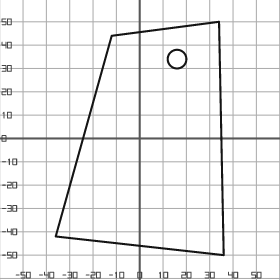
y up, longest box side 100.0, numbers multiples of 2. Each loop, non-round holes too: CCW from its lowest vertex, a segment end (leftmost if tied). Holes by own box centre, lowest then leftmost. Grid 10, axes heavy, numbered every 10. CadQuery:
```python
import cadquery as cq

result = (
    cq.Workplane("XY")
    .moveTo(36.0, -50.0)
    .lineTo(34.0, 50.0)
    .lineTo(-12.0, 44.0)
    .lineTo(-36.0, -42.0)
    .close()
    .moveTo(16.0, 34.0)
    .circle(4.0)
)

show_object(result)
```